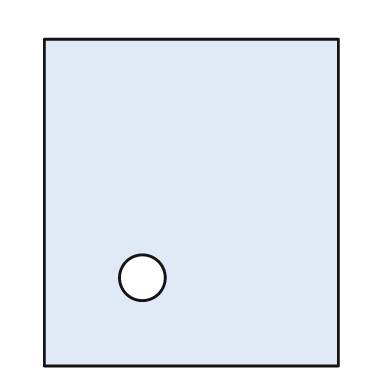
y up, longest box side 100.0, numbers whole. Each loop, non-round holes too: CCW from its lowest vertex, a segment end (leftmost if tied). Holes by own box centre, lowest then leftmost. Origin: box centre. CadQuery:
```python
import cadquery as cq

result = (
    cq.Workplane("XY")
    .moveTo(-45.0, -50.0)
    .lineTo(45.0, -50.0)
    .lineTo(45.0, 50.0)
    .lineTo(-45.0, 50.0)
    .close()
    .moveTo(-15.0, -23.0)
    .circle(7.0)
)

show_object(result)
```